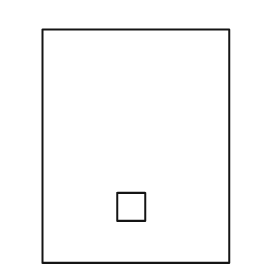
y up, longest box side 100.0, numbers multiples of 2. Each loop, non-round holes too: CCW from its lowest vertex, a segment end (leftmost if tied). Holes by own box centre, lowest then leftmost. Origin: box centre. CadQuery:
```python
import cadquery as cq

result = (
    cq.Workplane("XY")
    .moveTo(-40.0, -50.0)
    .lineTo(40.0, -50.0)
    .lineTo(40.0, 50.0)
    .lineTo(-40.0, 50.0)
    .close()
    .moveTo(-8.0, -32.0)
    .lineTo(4.0, -32.0)
    .lineTo(4.0, -20.0)
    .lineTo(-8.0, -20.0)
    .close()
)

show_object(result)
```